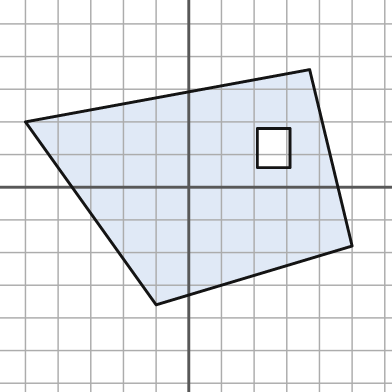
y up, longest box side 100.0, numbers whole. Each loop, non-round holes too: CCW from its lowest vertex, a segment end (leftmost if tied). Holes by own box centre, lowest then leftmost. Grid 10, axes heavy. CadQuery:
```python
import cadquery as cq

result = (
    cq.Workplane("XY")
    .moveTo(-10.0, -36.0)
    .lineTo(50.0, -18.0)
    .lineTo(37.0, 36.0)
    .lineTo(-50.0, 20.0)
    .close()
    .moveTo(21.0, 6.0)
    .lineTo(31.0, 6.0)
    .lineTo(31.0, 18.0)
    .lineTo(21.0, 18.0)
    .close()
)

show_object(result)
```